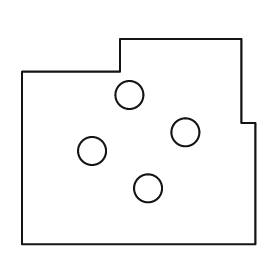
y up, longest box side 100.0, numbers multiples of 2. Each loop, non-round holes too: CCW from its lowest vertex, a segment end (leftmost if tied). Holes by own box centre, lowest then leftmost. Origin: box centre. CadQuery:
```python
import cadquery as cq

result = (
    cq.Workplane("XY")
    .moveTo(-50.0, -44.0)
    .lineTo(50.0, -44.0)
    .lineTo(50.0, 8.0)
    .lineTo(44.0, 8.0)
    .lineTo(44.0, 44.0)
    .lineTo(-8.0, 44.0)
    .lineTo(-8.0, 30.0)
    .lineTo(-50.0, 30.0)
    .close()
    .moveTo(4.0, -20.0)
    .circle(6.0)
    .moveTo(-20.0, -4.0)
    .circle(6.0)
    .moveTo(20.0, 4.0)
    .circle(6.0)
    .moveTo(-4.0, 20.0)
    .circle(6.0)
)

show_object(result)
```